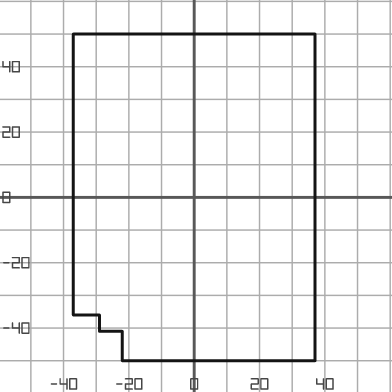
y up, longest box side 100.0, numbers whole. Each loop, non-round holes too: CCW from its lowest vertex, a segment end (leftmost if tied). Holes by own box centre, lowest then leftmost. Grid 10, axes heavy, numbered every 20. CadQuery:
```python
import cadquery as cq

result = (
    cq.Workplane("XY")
    .moveTo(-22.0, -50.0)
    .lineTo(37.0, -50.0)
    .lineTo(37.0, 50.0)
    .lineTo(-37.0, 50.0)
    .lineTo(-37.0, -36.0)
    .lineTo(-29.0, -36.0)
    .lineTo(-29.0, -41.0)
    .lineTo(-22.0, -41.0)
    .close()
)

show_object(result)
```